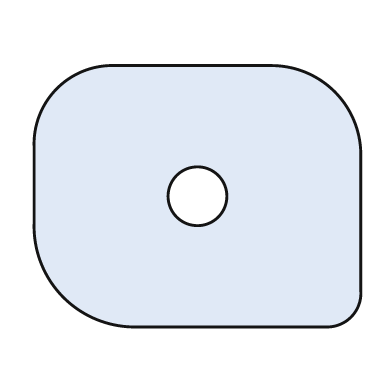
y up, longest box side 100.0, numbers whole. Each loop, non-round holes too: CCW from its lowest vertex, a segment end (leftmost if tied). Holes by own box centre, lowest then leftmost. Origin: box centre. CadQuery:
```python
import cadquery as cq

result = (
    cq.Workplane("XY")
    .moveTo(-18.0, -40.0)
    .lineTo(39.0, -40.0)
    .threePointArc((47.0, -37.0), (50.0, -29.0))
    .lineTo(50.0, 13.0)
    .threePointArc((42.0, 32.0), (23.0, 40.0))
    .lineTo(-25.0, 40.0)
    .threePointArc((-43.0, 33.0), (-50.0, 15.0))
    .lineTo(-50.0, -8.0)
    .threePointArc((-41.0, -31.0), (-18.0, -40.0))
    .close()
    .moveTo(0.0, 0.0)
    .circle(9.0)
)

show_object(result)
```